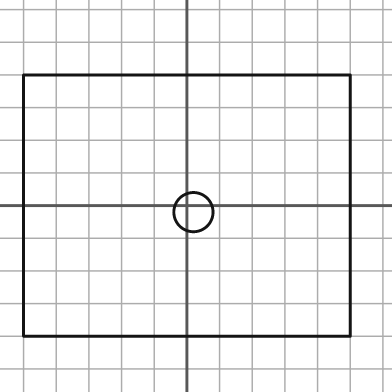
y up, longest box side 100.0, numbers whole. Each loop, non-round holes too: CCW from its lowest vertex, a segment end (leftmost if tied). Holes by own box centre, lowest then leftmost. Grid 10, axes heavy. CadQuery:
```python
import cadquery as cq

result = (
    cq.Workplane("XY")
    .moveTo(-50.0, -40.0)
    .lineTo(50.0, -40.0)
    .lineTo(50.0, 40.0)
    .lineTo(-50.0, 40.0)
    .close()
    .moveTo(2.0, -2.0)
    .circle(6.0)
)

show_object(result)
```